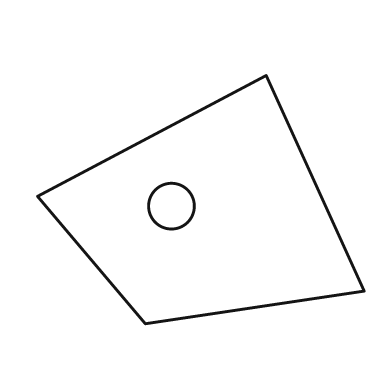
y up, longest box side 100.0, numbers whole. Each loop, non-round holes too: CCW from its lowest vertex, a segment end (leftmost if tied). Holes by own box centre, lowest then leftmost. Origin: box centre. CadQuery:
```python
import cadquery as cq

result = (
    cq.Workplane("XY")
    .moveTo(-17.0, -38.0)
    .lineTo(50.0, -28.0)
    .lineTo(20.0, 38.0)
    .lineTo(-50.0, 1.0)
    .close()
    .moveTo(-9.0, -2.0)
    .circle(7.0)
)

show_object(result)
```